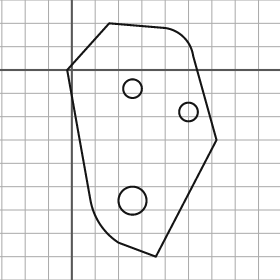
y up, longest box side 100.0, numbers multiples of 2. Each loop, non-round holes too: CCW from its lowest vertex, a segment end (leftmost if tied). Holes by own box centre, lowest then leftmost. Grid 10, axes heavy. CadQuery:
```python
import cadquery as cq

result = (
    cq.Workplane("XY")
    .moveTo(36.0, -80.0)
    .lineTo(62.0, -30.0)
    .lineTo(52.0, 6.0)
    .threePointArc((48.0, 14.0), (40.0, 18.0))
    .lineTo(16.0, 20.0)
    .lineTo(-2.0, 0.0)
    .lineTo(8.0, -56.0)
    .threePointArc((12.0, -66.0), (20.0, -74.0))
    .close()
    .moveTo(26.0, -56.0)
    .circle(6.0)
    .moveTo(50.0, -18.0)
    .circle(4.0)
    .moveTo(26.0, -8.0)
    .circle(4.0)
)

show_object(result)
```